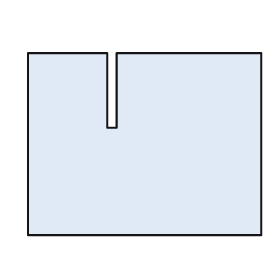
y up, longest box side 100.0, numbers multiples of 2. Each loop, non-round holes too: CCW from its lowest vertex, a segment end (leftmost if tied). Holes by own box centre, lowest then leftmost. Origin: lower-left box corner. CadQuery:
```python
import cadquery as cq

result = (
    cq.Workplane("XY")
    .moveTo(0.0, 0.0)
    .lineTo(100.0, 0.0)
    .lineTo(100.0, 78.0)
    .lineTo(38.0, 78.0)
    .lineTo(38.0, 46.0)
    .lineTo(34.0, 46.0)
    .lineTo(34.0, 78.0)
    .lineTo(0.0, 78.0)
    .close()
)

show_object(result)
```